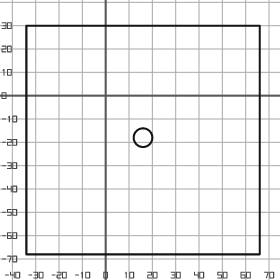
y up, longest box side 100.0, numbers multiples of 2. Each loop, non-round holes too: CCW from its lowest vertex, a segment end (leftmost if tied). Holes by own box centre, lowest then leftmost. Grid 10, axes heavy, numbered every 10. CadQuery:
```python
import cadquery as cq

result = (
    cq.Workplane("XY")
    .moveTo(-34.0, -68.0)
    .lineTo(66.0, -68.0)
    .lineTo(66.0, 30.0)
    .lineTo(-34.0, 30.0)
    .close()
    .moveTo(16.0, -18.0)
    .circle(4.0)
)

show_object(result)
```